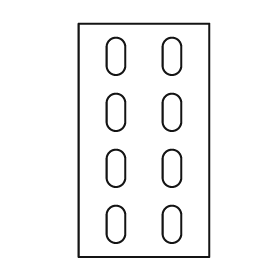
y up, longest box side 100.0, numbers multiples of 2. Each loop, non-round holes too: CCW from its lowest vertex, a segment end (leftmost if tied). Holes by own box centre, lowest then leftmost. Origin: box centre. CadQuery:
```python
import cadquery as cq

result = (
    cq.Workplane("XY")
    .moveTo(-28.0, -50.0)
    .lineTo(28.0, -50.0)
    .lineTo(28.0, 50.0)
    .lineTo(-28.0, 50.0)
    .close()
    .moveTo(-16.0, -40.0)
    .threePointArc((-12.0, -44.0), (-8.0, -40.0))
    .lineTo(-8.0, -32.0)
    .threePointArc((-12.0, -28.0), (-16.0, -32.0))
    .close()
    .moveTo(8.0, -40.0)
    .threePointArc((12.0, -44.0), (16.0, -40.0))
    .lineTo(16.0, -32.0)
    .threePointArc((12.0, -28.0), (8.0, -32.0))
    .close()
    .moveTo(-16.0, -16.0)
    .threePointArc((-12.0, -20.0), (-8.0, -16.0))
    .lineTo(-8.0, -8.0)
    .threePointArc((-12.0, -4.0), (-16.0, -8.0))
    .close()
    .moveTo(8.0, -16.0)
    .threePointArc((12.0, -20.0), (16.0, -16.0))
    .lineTo(16.0, -8.0)
    .threePointArc((12.0, -4.0), (8.0, -8.0))
    .close()
    .moveTo(-16.0, 8.0)
    .threePointArc((-12.0, 4.0), (-8.0, 8.0))
    .lineTo(-8.0, 16.0)
    .threePointArc((-12.0, 20.0), (-16.0, 16.0))
    .close()
    .moveTo(8.0, 8.0)
    .threePointArc((12.0, 4.0), (16.0, 8.0))
    .lineTo(16.0, 16.0)
    .threePointArc((12.0, 20.0), (8.0, 16.0))
    .close()
    .moveTo(-16.0, 32.0)
    .threePointArc((-12.0, 28.0), (-8.0, 32.0))
    .lineTo(-8.0, 40.0)
    .threePointArc((-12.0, 44.0), (-16.0, 40.0))
    .close()
    .moveTo(8.0, 32.0)
    .threePointArc((12.0, 28.0), (16.0, 32.0))
    .lineTo(16.0, 40.0)
    .threePointArc((12.0, 44.0), (8.0, 40.0))
    .close()
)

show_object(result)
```